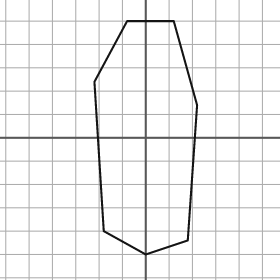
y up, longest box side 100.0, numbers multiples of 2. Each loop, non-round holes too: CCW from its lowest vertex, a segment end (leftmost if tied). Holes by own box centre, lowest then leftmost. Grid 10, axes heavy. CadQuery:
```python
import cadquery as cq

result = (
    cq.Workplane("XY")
    .moveTo(0.0, -50.0)
    .lineTo(18.0, -44.0)
    .lineTo(22.0, 14.0)
    .lineTo(12.0, 50.0)
    .lineTo(-8.0, 50.0)
    .lineTo(-22.0, 24.0)
    .lineTo(-18.0, -40.0)
    .close()
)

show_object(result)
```